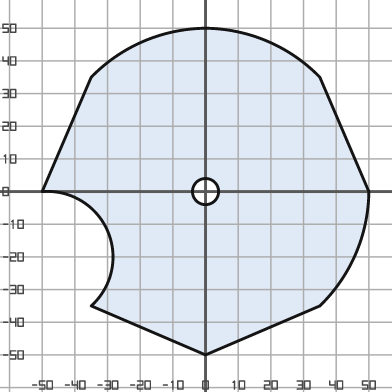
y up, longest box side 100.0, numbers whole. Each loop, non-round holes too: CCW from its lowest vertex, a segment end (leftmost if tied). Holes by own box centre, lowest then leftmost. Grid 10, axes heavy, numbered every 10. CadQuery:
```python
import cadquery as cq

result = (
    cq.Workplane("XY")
    .moveTo(0.0, -50.0)
    .lineTo(35.0, -35.0)
    .threePointArc((46.0, -19.0), (50.0, 0.0))
    .lineTo(35.0, 35.0)
    .threePointArc((19.0, 46.0), (0.0, 50.0))
    .threePointArc((-19.0, 46.0), (-35.0, 35.0))
    .lineTo(-50.0, 0.0)
    .threePointArc((-30.0, -12.0), (-35.0, -35.0))
    .close()
    .moveTo(0.0, 0.0)
    .circle(4.0)
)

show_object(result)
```